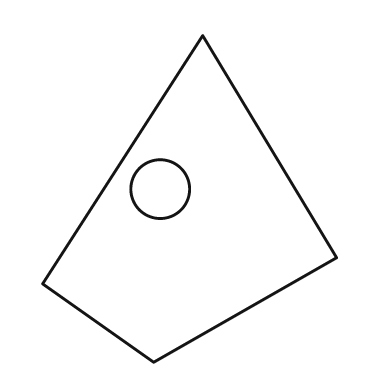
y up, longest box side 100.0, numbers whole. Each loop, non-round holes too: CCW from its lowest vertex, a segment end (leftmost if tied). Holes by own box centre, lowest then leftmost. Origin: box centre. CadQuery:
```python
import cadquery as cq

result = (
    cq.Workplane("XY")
    .moveTo(-11.0, -50.0)
    .lineTo(45.0, -18.0)
    .lineTo(4.0, 50.0)
    .lineTo(-45.0, -26.0)
    .close()
    .moveTo(-9.0, 3.0)
    .circle(9.0)
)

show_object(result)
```